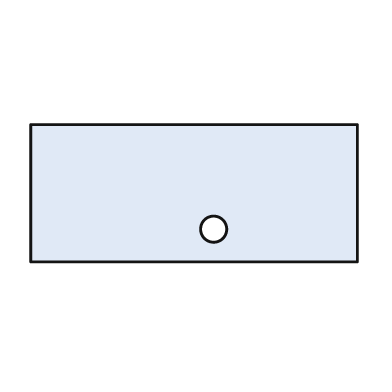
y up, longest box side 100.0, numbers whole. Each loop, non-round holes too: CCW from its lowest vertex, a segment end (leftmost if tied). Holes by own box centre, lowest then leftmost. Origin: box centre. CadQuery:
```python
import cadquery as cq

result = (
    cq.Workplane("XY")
    .moveTo(-50.0, -21.0)
    .lineTo(50.0, -21.0)
    .lineTo(50.0, 21.0)
    .lineTo(-50.0, 21.0)
    .close()
    .moveTo(6.0, -11.0)
    .circle(4.0)
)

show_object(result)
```